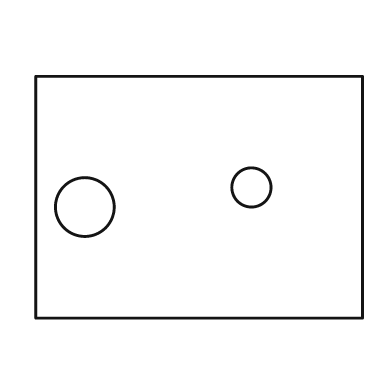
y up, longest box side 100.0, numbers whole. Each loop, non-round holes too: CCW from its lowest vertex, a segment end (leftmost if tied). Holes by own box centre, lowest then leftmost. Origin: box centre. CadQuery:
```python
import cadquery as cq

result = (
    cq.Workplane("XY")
    .moveTo(-50.0, -37.0)
    .lineTo(50.0, -37.0)
    .lineTo(50.0, 37.0)
    .lineTo(-50.0, 37.0)
    .close()
    .moveTo(-35.0, -3.0)
    .circle(9.0)
    .moveTo(16.0, 3.0)
    .circle(6.0)
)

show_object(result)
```